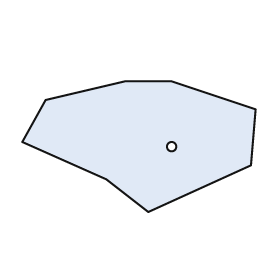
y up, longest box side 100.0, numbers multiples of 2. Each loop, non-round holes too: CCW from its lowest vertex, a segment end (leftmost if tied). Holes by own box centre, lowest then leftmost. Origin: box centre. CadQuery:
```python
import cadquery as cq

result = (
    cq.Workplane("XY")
    .moveTo(4.0, -28.0)
    .lineTo(48.0, -8.0)
    .lineTo(50.0, 16.0)
    .lineTo(14.0, 28.0)
    .lineTo(-6.0, 28.0)
    .lineTo(-40.0, 20.0)
    .lineTo(-50.0, 2.0)
    .lineTo(-14.0, -14.0)
    .close()
    .moveTo(14.0, 0.0)
    .circle(2.0)
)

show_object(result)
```